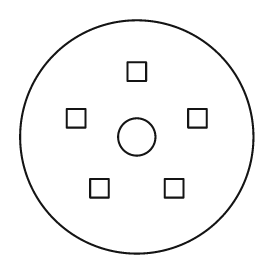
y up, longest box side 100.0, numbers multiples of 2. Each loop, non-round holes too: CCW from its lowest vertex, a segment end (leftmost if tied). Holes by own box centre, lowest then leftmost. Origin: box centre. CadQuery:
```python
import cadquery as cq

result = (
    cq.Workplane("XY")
    .moveTo(0.0, 0.0)
    .circle(50.0)
    .moveTo(-20.0, -26.0)
    .lineTo(-12.0, -26.0)
    .lineTo(-12.0, -18.0)
    .lineTo(-20.0, -18.0)
    .close()
    .moveTo(12.0, -26.0)
    .lineTo(20.0, -26.0)
    .lineTo(20.0, -18.0)
    .lineTo(12.0, -18.0)
    .close()
    .moveTo(0.0, 0.0)
    .circle(8.0)
    .moveTo(-30.0, 4.0)
    .lineTo(-22.0, 4.0)
    .lineTo(-22.0, 12.0)
    .lineTo(-30.0, 12.0)
    .close()
    .moveTo(22.0, 4.0)
    .lineTo(30.0, 4.0)
    .lineTo(30.0, 12.0)
    .lineTo(22.0, 12.0)
    .close()
    .moveTo(-4.0, 24.0)
    .lineTo(4.0, 24.0)
    .lineTo(4.0, 32.0)
    .lineTo(-4.0, 32.0)
    .close()
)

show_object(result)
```